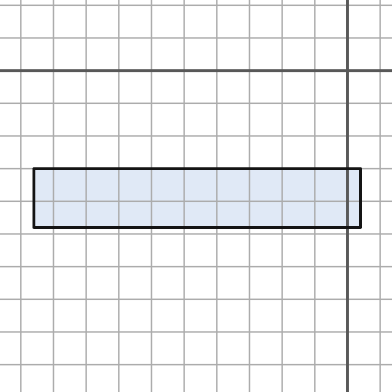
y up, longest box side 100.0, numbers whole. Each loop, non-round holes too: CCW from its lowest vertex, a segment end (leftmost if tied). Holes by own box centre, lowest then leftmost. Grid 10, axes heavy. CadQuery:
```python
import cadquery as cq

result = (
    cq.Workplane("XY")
    .moveTo(-96.0, -48.0)
    .lineTo(4.0, -48.0)
    .lineTo(4.0, -30.0)
    .lineTo(-96.0, -30.0)
    .close()
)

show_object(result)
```